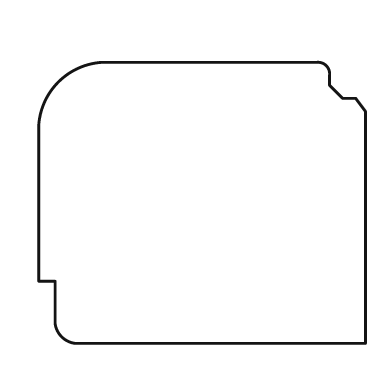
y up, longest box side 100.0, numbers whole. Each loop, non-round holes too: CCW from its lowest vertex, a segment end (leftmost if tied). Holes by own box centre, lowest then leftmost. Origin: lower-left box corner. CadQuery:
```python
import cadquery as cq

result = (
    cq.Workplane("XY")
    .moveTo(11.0, 0.0)
    .lineTo(100.0, 0.0)
    .lineTo(100.0, 71.0)
    .lineTo(97.0, 75.0)
    .lineTo(93.0, 75.0)
    .lineTo(89.0, 79.0)
    .lineTo(89.0, 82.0)
    .threePointArc((88.0, 85.0), (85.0, 86.0))
    .lineTo(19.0, 86.0)
    .threePointArc((6.0, 80.0), (0.0, 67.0))
    .lineTo(0.0, 19.0)
    .lineTo(5.0, 19.0)
    .lineTo(5.0, 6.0)
    .threePointArc((7.0, 2.0), (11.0, 0.0))
    .close()
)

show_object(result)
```